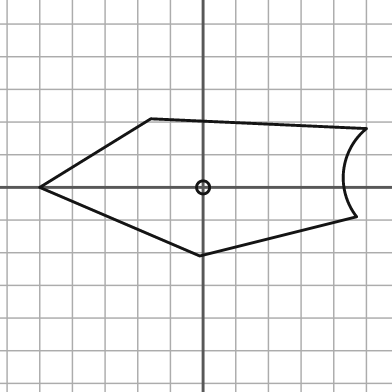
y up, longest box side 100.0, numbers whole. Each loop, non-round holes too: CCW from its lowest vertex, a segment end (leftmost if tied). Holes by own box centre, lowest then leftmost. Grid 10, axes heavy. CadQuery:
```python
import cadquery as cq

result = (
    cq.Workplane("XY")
    .moveTo(-1.0, -21.0)
    .lineTo(47.0, -9.0)
    .threePointArc((43.0, 5.0), (50.0, 18.0))
    .lineTo(-16.0, 21.0)
    .lineTo(-50.0, 0.0)
    .close()
    .moveTo(0.0, 0.0)
    .circle(2.0)
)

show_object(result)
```